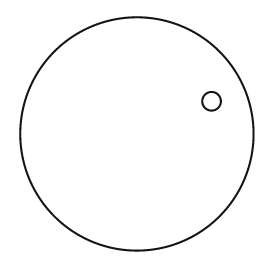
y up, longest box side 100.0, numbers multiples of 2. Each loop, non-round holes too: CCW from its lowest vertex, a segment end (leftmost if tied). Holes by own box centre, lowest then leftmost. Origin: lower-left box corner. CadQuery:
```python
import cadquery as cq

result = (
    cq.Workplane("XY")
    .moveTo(50.0, 50.0)
    .circle(50.0)
    .moveTo(82.0, 64.0)
    .circle(4.0)
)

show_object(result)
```